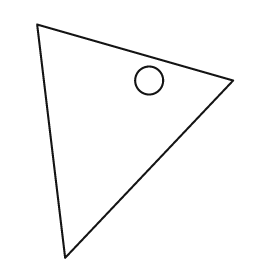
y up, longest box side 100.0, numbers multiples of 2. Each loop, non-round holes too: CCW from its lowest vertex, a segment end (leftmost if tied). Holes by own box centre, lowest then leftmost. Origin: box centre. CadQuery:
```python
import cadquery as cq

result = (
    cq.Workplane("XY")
    .moveTo(-30.0, -50.0)
    .lineTo(42.0, 26.0)
    .lineTo(-42.0, 50.0)
    .close()
    .moveTo(6.0, 26.0)
    .circle(6.0)
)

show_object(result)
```